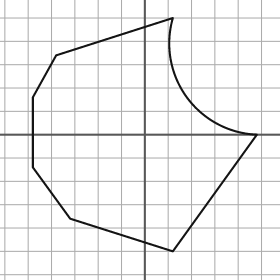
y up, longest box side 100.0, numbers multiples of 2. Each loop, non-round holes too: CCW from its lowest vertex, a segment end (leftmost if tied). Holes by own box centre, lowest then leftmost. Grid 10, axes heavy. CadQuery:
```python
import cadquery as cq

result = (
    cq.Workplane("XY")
    .moveTo(12.0, -50.0)
    .lineTo(48.0, 0.0)
    .threePointArc((18.0, 16.0), (12.0, 50.0))
    .lineTo(-38.0, 34.0)
    .lineTo(-48.0, 16.0)
    .lineTo(-48.0, -14.0)
    .lineTo(-32.0, -36.0)
    .close()
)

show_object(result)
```